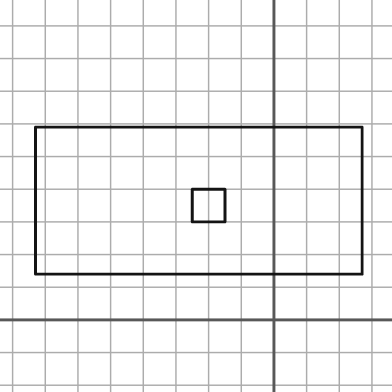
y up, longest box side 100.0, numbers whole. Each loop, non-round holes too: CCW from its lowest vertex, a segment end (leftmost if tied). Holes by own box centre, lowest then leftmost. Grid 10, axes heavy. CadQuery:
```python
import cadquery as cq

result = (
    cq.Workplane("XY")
    .moveTo(-73.0, 14.0)
    .lineTo(27.0, 14.0)
    .lineTo(27.0, 59.0)
    .lineTo(-73.0, 59.0)
    .close()
    .moveTo(-25.0, 30.0)
    .lineTo(-15.0, 30.0)
    .lineTo(-15.0, 40.0)
    .lineTo(-25.0, 40.0)
    .close()
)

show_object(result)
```